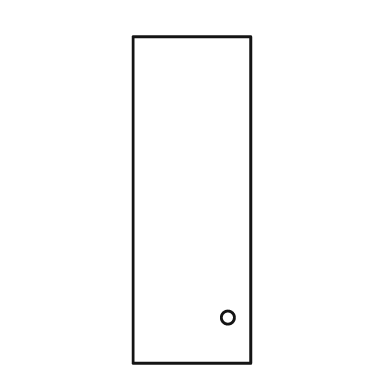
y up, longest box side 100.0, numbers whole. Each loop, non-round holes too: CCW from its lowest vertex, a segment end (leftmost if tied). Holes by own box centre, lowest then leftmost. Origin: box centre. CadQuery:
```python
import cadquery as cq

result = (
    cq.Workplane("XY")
    .moveTo(-18.0, -50.0)
    .lineTo(18.0, -50.0)
    .lineTo(18.0, 50.0)
    .lineTo(-18.0, 50.0)
    .close()
    .moveTo(11.0, -36.0)
    .circle(2.0)
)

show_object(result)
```